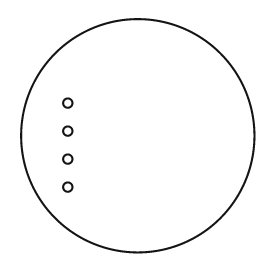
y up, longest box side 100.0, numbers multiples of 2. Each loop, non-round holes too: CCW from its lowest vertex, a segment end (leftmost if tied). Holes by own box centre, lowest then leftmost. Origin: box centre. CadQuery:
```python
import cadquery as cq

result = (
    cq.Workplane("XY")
    .moveTo(0.0, 0.0)
    .circle(50.0)
    .moveTo(-30.0, -22.0)
    .circle(2.0)
    .moveTo(-30.0, -10.0)
    .circle(2.0)
    .moveTo(-30.0, 2.0)
    .circle(2.0)
    .moveTo(-30.0, 14.0)
    .circle(2.0)
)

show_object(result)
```